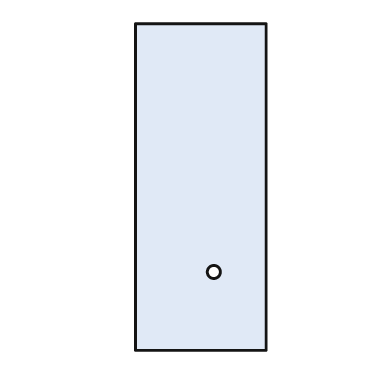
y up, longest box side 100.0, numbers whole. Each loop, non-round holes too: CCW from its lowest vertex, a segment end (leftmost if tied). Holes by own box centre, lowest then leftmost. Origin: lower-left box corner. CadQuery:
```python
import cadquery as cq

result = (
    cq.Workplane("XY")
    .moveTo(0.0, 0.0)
    .lineTo(40.0, 0.0)
    .lineTo(40.0, 100.0)
    .lineTo(0.0, 100.0)
    .close()
    .moveTo(24.0, 24.0)
    .circle(2.0)
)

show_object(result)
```